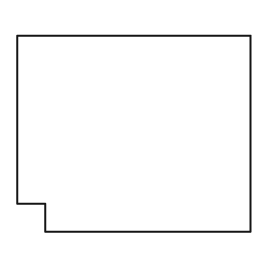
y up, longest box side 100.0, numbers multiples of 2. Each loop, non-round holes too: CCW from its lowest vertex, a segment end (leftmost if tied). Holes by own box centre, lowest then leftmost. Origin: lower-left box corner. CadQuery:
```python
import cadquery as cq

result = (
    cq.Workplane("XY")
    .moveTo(12.0, 0.0)
    .lineTo(100.0, 0.0)
    .lineTo(100.0, 84.0)
    .lineTo(0.0, 84.0)
    .lineTo(0.0, 12.0)
    .lineTo(12.0, 12.0)
    .close()
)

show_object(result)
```